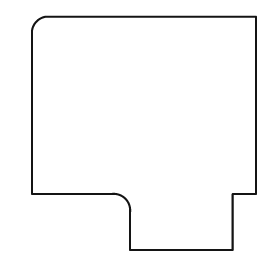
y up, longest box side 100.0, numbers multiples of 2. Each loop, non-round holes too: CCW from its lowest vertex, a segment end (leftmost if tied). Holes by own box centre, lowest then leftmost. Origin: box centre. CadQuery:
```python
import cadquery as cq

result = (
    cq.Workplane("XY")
    .moveTo(-6.0, -50.0)
    .lineTo(38.0, -50.0)
    .lineTo(38.0, -26.0)
    .lineTo(48.0, -26.0)
    .lineTo(48.0, 50.0)
    .lineTo(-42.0, 50.0)
    .threePointArc((-46.0, 48.0), (-48.0, 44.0))
    .lineTo(-48.0, -26.0)
    .lineTo(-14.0, -26.0)
    .threePointArc((-8.0, -28.0), (-6.0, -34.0))
    .close()
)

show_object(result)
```